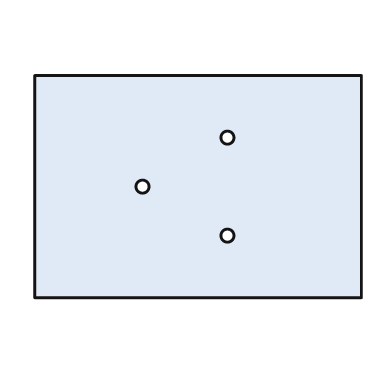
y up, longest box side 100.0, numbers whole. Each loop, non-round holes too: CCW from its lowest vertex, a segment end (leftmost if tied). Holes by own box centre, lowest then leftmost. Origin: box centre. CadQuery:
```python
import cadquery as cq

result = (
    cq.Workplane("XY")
    .moveTo(-50.0, -34.0)
    .lineTo(50.0, -34.0)
    .lineTo(50.0, 34.0)
    .lineTo(-50.0, 34.0)
    .close()
    .moveTo(9.0, -15.0)
    .circle(2.0)
    .moveTo(-17.0, 0.0)
    .circle(2.0)
    .moveTo(9.0, 15.0)
    .circle(2.0)
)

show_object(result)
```